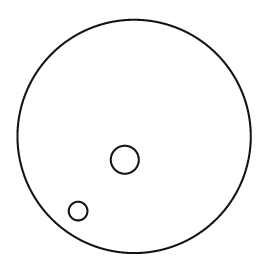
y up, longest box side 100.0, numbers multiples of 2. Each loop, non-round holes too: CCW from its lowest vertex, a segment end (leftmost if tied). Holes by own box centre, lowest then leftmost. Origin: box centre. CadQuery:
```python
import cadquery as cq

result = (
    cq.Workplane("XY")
    .moveTo(0.0, 0.0)
    .circle(50.0)
    .moveTo(-24.0, -32.0)
    .circle(4.0)
    .moveTo(-4.0, -10.0)
    .circle(6.0)
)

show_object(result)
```